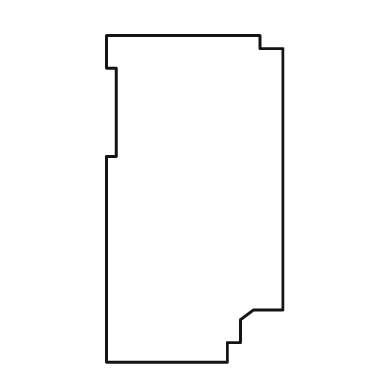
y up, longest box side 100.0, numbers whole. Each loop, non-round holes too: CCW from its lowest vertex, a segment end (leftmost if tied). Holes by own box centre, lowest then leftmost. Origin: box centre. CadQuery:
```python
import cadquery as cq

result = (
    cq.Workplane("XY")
    .moveTo(-27.0, -50.0)
    .lineTo(10.0, -50.0)
    .lineTo(10.0, -44.0)
    .lineTo(14.0, -44.0)
    .lineTo(14.0, -37.0)
    .lineTo(18.0, -34.0)
    .lineTo(27.0, -34.0)
    .lineTo(27.0, 46.0)
    .lineTo(20.0, 46.0)
    .lineTo(20.0, 50.0)
    .lineTo(-27.0, 50.0)
    .lineTo(-27.0, 40.0)
    .lineTo(-24.0, 40.0)
    .lineTo(-24.0, 13.0)
    .lineTo(-27.0, 13.0)
    .close()
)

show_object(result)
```